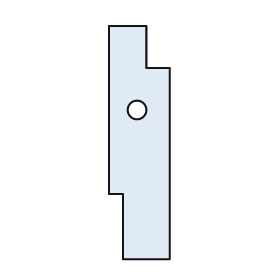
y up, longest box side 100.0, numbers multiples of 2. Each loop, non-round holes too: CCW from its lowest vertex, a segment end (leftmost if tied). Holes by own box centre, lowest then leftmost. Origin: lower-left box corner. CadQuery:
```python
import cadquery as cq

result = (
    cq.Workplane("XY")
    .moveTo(6.0, 0.0)
    .lineTo(26.0, 0.0)
    .lineTo(26.0, 82.0)
    .lineTo(16.0, 82.0)
    .lineTo(16.0, 100.0)
    .lineTo(0.0, 100.0)
    .lineTo(0.0, 28.0)
    .lineTo(6.0, 28.0)
    .close()
    .moveTo(12.0, 64.0)
    .circle(4.0)
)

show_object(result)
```